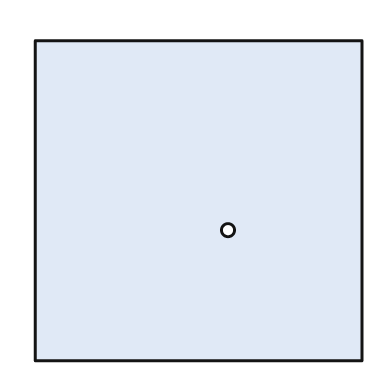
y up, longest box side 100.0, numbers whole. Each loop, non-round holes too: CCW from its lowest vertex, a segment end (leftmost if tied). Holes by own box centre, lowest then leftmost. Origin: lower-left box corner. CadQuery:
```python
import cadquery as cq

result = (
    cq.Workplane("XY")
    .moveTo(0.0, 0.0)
    .lineTo(100.0, 0.0)
    .lineTo(100.0, 98.0)
    .lineTo(0.0, 98.0)
    .close()
    .moveTo(59.0, 40.0)
    .circle(2.0)
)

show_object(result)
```